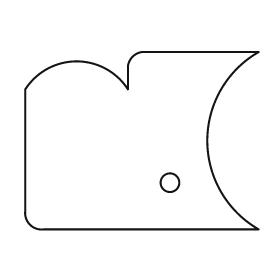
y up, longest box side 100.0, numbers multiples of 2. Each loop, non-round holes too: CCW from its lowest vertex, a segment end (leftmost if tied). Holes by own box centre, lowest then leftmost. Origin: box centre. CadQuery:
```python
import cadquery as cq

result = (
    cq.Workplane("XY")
    .moveTo(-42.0, -38.0)
    .lineTo(50.0, -38.0)
    .threePointArc((28.0, 0.0), (50.0, 38.0))
    .lineTo(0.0, 38.0)
    .threePointArc((-4.0, 36.0), (-6.0, 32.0))
    .lineTo(-6.0, 22.0)
    .threePointArc((-28.0, 34.0), (-50.0, 22.0))
    .lineTo(-50.0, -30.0)
    .threePointArc((-48.0, -36.0), (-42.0, -38.0))
    .close()
    .moveTo(12.0, -18.0)
    .circle(4.0)
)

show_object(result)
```